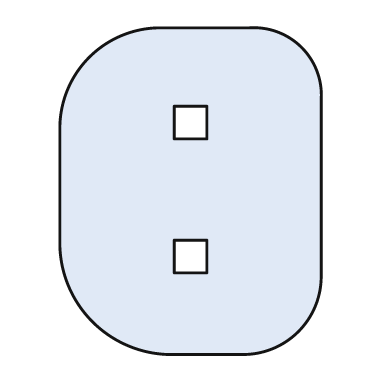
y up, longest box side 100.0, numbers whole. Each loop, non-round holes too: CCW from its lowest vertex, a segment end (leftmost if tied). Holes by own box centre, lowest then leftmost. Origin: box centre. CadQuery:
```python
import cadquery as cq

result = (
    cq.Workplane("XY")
    .moveTo(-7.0, -50.0)
    .lineTo(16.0, -50.0)
    .threePointArc((33.0, -43.0), (40.0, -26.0))
    .lineTo(40.0, 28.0)
    .threePointArc((34.0, 44.0), (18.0, 50.0))
    .lineTo(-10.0, 50.0)
    .threePointArc((-31.0, 41.0), (-40.0, 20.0))
    .lineTo(-40.0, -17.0)
    .threePointArc((-30.0, -40.0), (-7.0, -50.0))
    .close()
    .moveTo(-5.0, -25.0)
    .lineTo(5.0, -25.0)
    .lineTo(5.0, -15.0)
    .lineTo(-5.0, -15.0)
    .close()
    .moveTo(-5.0, 16.0)
    .lineTo(5.0, 16.0)
    .lineTo(5.0, 26.0)
    .lineTo(-5.0, 26.0)
    .close()
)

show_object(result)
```